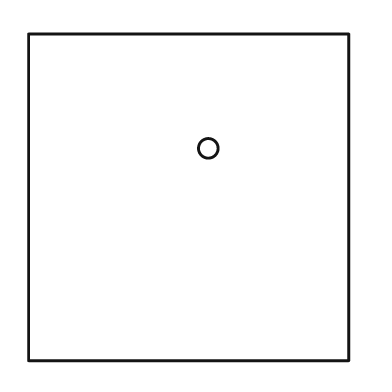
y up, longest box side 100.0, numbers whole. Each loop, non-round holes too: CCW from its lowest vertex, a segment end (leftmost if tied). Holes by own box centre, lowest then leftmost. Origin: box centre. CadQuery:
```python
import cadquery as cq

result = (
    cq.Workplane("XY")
    .moveTo(-49.0, -50.0)
    .lineTo(49.0, -50.0)
    .lineTo(49.0, 50.0)
    .lineTo(-49.0, 50.0)
    .close()
    .moveTo(6.0, 15.0)
    .circle(3.0)
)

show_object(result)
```